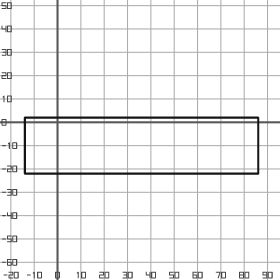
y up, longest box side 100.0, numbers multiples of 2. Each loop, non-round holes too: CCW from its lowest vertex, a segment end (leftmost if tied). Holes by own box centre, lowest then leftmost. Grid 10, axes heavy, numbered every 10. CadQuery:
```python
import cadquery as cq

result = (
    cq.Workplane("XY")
    .moveTo(-14.0, -22.0)
    .lineTo(86.0, -22.0)
    .lineTo(86.0, 2.0)
    .lineTo(-14.0, 2.0)
    .close()
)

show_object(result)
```